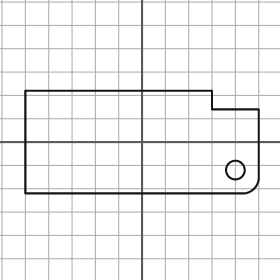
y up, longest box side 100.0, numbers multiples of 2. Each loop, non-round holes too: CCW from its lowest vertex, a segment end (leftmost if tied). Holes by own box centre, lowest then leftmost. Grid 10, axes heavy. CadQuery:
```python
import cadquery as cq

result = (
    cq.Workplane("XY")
    .moveTo(-50.0, -22.0)
    .lineTo(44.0, -22.0)
    .threePointArc((48.0, -20.0), (50.0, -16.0))
    .lineTo(50.0, 14.0)
    .lineTo(30.0, 14.0)
    .lineTo(30.0, 22.0)
    .lineTo(-50.0, 22.0)
    .close()
    .moveTo(40.0, -12.0)
    .circle(4.0)
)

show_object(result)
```